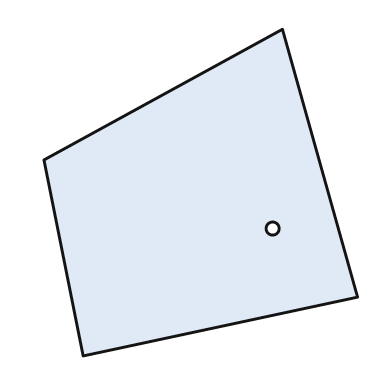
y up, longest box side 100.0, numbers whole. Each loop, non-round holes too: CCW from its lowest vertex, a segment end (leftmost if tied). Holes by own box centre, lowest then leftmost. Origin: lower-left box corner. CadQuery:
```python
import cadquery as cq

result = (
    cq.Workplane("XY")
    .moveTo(12.0, 0.0)
    .lineTo(96.0, 18.0)
    .lineTo(73.0, 100.0)
    .lineTo(0.0, 60.0)
    .close()
    .moveTo(70.0, 39.0)
    .circle(2.0)
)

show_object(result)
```